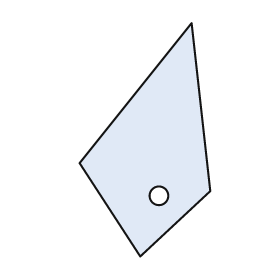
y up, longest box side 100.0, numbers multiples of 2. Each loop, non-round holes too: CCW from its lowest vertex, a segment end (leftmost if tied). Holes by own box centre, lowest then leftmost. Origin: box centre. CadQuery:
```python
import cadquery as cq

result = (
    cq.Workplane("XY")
    .moveTo(-2.0, -50.0)
    .lineTo(28.0, -22.0)
    .lineTo(20.0, 50.0)
    .lineTo(-28.0, -10.0)
    .close()
    .moveTo(6.0, -24.0)
    .circle(4.0)
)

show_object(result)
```